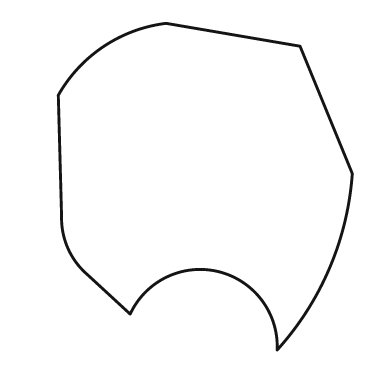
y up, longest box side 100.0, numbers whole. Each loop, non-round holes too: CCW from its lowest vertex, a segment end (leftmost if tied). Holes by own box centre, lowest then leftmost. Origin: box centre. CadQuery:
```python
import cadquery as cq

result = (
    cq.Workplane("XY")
    .moveTo(22.0, -50.0)
    .threePointArc((38.0, -25.0), (45.0, 4.0))
    .lineTo(29.0, 43.0)
    .lineTo(-12.0, 50.0)
    .threePointArc((-31.0, 43.0), (-45.0, 28.0))
    .lineTo(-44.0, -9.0)
    .threePointArc((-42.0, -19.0), (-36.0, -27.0))
    .lineTo(-23.0, -39.0)
    .threePointArc((4.0, -26.0), (22.0, -50.0))
    .close()
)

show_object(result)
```